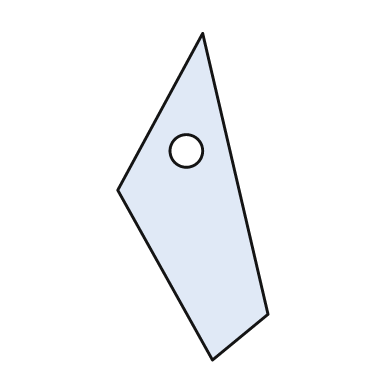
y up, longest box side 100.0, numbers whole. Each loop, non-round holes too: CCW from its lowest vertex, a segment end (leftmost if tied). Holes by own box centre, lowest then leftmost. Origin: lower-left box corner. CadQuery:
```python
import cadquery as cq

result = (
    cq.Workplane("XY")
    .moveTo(29.0, 0.0)
    .lineTo(46.0, 14.0)
    .lineTo(26.0, 100.0)
    .lineTo(0.0, 52.0)
    .close()
    .moveTo(21.0, 64.0)
    .circle(5.0)
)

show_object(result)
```